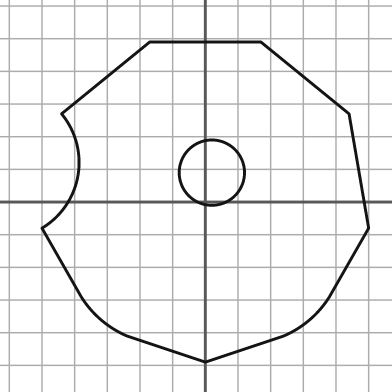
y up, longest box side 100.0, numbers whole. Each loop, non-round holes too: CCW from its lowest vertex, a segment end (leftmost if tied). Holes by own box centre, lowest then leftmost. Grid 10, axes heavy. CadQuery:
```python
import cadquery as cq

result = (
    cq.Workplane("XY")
    .moveTo(0.0, -49.0)
    .lineTo(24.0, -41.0)
    .threePointArc((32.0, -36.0), (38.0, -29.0))
    .lineTo(50.0, -8.0)
    .lineTo(44.0, 27.0)
    .lineTo(17.0, 49.0)
    .lineTo(-17.0, 49.0)
    .lineTo(-44.0, 27.0)
    .threePointArc((-39.0, 8.0), (-50.0, -8.0))
    .lineTo(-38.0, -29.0)
    .threePointArc((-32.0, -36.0), (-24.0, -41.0))
    .close()
    .moveTo(2.0, 9.0)
    .circle(10.0)
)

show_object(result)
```